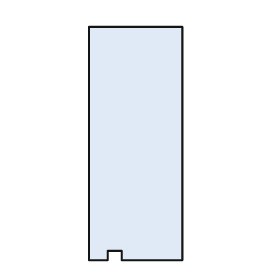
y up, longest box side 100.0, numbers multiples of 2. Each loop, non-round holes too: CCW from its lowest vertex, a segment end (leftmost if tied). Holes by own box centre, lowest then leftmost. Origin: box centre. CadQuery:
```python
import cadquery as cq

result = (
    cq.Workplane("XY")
    .moveTo(-20.0, -50.0)
    .lineTo(-12.0, -50.0)
    .lineTo(-12.0, -46.0)
    .lineTo(-6.0, -46.0)
    .lineTo(-6.0, -50.0)
    .lineTo(20.0, -50.0)
    .lineTo(20.0, 50.0)
    .lineTo(-20.0, 50.0)
    .close()
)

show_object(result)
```